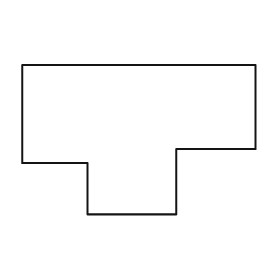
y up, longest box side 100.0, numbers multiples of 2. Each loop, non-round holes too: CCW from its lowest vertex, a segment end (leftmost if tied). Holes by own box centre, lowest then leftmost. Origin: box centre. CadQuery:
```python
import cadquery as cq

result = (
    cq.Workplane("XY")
    .moveTo(-22.0, -32.0)
    .lineTo(16.0, -32.0)
    .lineTo(16.0, -4.0)
    .lineTo(50.0, -4.0)
    .lineTo(50.0, 32.0)
    .lineTo(-50.0, 32.0)
    .lineTo(-50.0, -10.0)
    .lineTo(-22.0, -10.0)
    .close()
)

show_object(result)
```